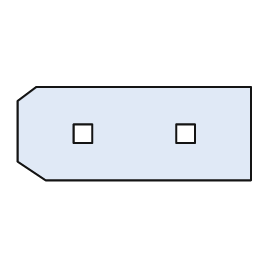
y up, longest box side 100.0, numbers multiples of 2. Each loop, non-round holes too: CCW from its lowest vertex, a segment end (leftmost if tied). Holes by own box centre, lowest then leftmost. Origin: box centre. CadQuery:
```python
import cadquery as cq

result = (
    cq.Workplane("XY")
    .moveTo(-38.0, -20.0)
    .lineTo(50.0, -20.0)
    .lineTo(50.0, 20.0)
    .lineTo(-42.0, 20.0)
    .lineTo(-50.0, 14.0)
    .lineTo(-50.0, -12.0)
    .close()
    .moveTo(-26.0, -4.0)
    .lineTo(-18.0, -4.0)
    .lineTo(-18.0, 4.0)
    .lineTo(-26.0, 4.0)
    .close()
    .moveTo(18.0, -4.0)
    .lineTo(26.0, -4.0)
    .lineTo(26.0, 4.0)
    .lineTo(18.0, 4.0)
    .close()
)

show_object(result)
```